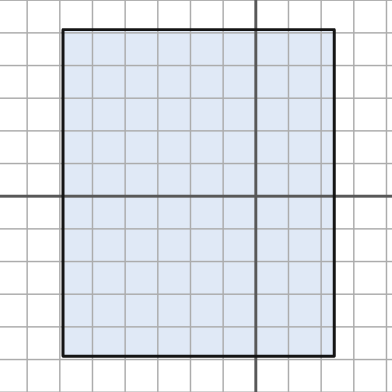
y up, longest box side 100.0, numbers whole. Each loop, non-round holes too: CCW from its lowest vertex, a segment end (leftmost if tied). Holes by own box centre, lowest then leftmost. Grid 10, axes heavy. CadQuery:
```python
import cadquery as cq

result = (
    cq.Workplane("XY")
    .moveTo(-59.0, -49.0)
    .lineTo(24.0, -49.0)
    .lineTo(24.0, 51.0)
    .lineTo(-59.0, 51.0)
    .close()
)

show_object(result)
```